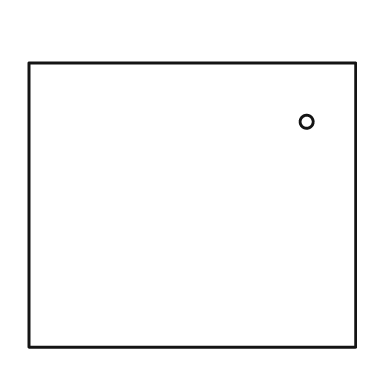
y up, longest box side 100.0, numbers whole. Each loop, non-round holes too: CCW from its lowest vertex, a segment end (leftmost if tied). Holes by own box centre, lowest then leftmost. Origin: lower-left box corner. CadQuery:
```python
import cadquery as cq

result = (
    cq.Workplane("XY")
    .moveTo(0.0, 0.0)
    .lineTo(100.0, 0.0)
    .lineTo(100.0, 87.0)
    .lineTo(0.0, 87.0)
    .close()
    .moveTo(85.0, 69.0)
    .circle(2.0)
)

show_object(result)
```